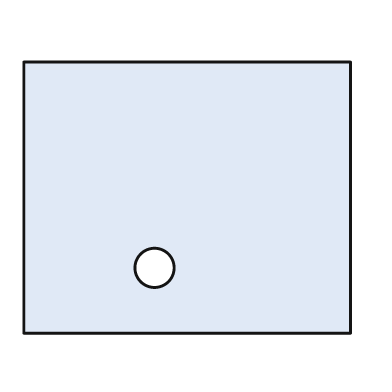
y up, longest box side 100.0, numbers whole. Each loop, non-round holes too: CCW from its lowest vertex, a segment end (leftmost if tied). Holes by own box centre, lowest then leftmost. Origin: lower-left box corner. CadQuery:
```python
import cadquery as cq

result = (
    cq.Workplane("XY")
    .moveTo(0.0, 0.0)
    .lineTo(100.0, 0.0)
    .lineTo(100.0, 83.0)
    .lineTo(0.0, 83.0)
    .close()
    .moveTo(40.0, 20.0)
    .circle(6.0)
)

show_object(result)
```